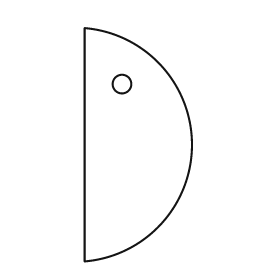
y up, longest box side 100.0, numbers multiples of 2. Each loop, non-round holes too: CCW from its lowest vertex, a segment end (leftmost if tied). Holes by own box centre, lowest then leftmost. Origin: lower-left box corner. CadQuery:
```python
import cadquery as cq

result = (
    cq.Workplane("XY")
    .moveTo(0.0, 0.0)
    .threePointArc((46.0, 50.0), (0.0, 100.0))
    .close()
    .moveTo(16.0, 76.0)
    .circle(4.0)
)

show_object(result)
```